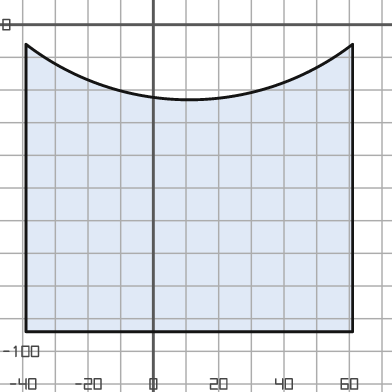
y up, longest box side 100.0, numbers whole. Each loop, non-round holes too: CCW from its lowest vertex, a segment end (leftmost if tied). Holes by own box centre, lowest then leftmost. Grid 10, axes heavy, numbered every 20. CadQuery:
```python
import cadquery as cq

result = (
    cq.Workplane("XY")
    .moveTo(-39.0, -94.0)
    .lineTo(61.0, -94.0)
    .lineTo(61.0, -6.0)
    .threePointArc((11.0, -23.0), (-39.0, -6.0))
    .close()
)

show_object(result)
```